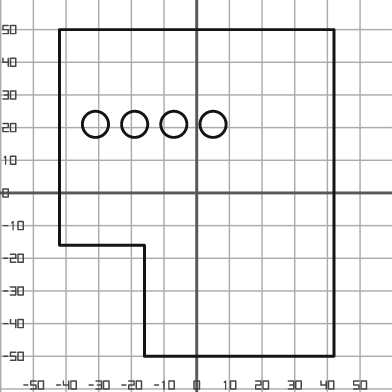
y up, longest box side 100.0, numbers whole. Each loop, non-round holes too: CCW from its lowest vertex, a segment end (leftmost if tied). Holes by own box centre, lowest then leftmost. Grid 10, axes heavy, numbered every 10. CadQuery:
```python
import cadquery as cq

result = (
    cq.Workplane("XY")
    .moveTo(-16.0, -50.0)
    .lineTo(42.0, -50.0)
    .lineTo(42.0, 50.0)
    .lineTo(-42.0, 50.0)
    .lineTo(-42.0, -16.0)
    .lineTo(-16.0, -16.0)
    .close()
    .moveTo(-31.0, 21.0)
    .circle(4.0)
    .moveTo(-19.0, 21.0)
    .circle(4.0)
    .moveTo(-7.0, 21.0)
    .circle(4.0)
    .moveTo(5.0, 21.0)
    .circle(4.0)
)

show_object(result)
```